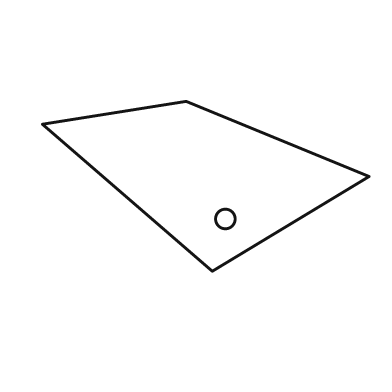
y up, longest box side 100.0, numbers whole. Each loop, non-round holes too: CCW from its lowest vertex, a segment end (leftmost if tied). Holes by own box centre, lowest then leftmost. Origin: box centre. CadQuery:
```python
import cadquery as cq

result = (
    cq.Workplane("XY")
    .moveTo(2.0, -26.0)
    .lineTo(50.0, 3.0)
    .lineTo(-6.0, 26.0)
    .lineTo(-50.0, 19.0)
    .close()
    .moveTo(6.0, -10.0)
    .circle(3.0)
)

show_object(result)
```